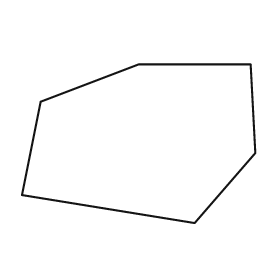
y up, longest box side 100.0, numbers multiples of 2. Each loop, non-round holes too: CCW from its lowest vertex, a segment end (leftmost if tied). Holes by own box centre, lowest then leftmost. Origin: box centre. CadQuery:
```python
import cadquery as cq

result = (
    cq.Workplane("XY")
    .moveTo(24.0, -34.0)
    .lineTo(50.0, -4.0)
    .lineTo(48.0, 34.0)
    .lineTo(0.0, 34.0)
    .lineTo(-42.0, 18.0)
    .lineTo(-50.0, -22.0)
    .close()
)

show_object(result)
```